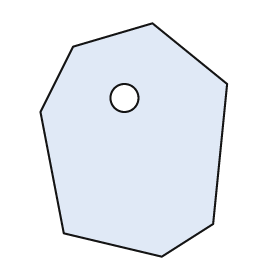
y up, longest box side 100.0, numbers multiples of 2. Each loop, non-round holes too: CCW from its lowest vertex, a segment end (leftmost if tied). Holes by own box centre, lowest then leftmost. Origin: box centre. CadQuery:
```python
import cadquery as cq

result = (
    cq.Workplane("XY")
    .moveTo(12.0, -50.0)
    .lineTo(34.0, -36.0)
    .lineTo(40.0, 24.0)
    .lineTo(8.0, 50.0)
    .lineTo(-26.0, 40.0)
    .lineTo(-40.0, 12.0)
    .lineTo(-30.0, -40.0)
    .close()
    .moveTo(-4.0, 18.0)
    .circle(6.0)
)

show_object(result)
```